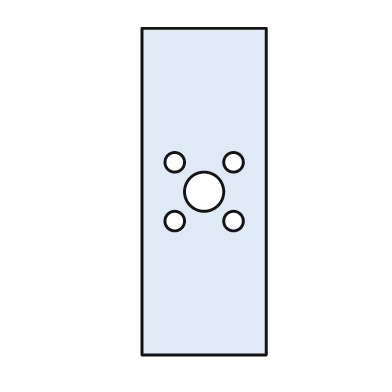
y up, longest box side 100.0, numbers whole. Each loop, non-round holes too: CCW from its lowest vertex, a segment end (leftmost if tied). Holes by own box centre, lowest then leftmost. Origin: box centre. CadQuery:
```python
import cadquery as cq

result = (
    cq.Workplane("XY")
    .moveTo(-19.0, -50.0)
    .lineTo(19.0, -50.0)
    .lineTo(19.0, 50.0)
    .lineTo(-19.0, 50.0)
    .close()
    .moveTo(-9.0, -9.0)
    .circle(3.0)
    .moveTo(9.0, -9.0)
    .circle(3.0)
    .moveTo(0.0, 0.0)
    .circle(6.0)
    .moveTo(-9.0, 9.0)
    .circle(3.0)
    .moveTo(9.0, 9.0)
    .circle(3.0)
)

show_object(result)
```